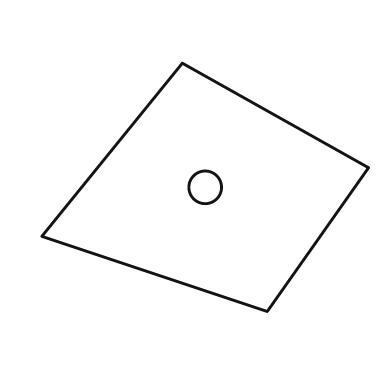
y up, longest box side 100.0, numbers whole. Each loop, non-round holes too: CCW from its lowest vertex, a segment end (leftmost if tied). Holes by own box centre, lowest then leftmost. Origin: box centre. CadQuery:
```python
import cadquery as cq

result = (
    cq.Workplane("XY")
    .moveTo(19.0, -38.0)
    .lineTo(50.0, 6.0)
    .lineTo(-7.0, 38.0)
    .lineTo(-50.0, -15.0)
    .close()
    .moveTo(0.0, 0.0)
    .circle(5.0)
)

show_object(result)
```